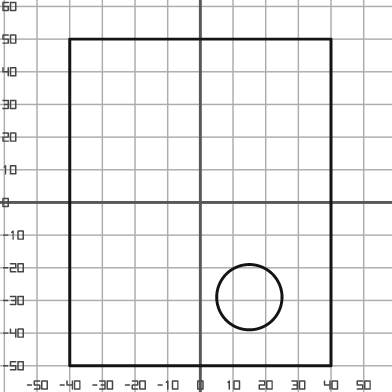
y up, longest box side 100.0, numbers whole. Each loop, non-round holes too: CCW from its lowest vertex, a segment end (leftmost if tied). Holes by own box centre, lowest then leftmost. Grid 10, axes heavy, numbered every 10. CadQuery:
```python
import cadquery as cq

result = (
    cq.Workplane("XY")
    .moveTo(-40.0, -50.0)
    .lineTo(40.0, -50.0)
    .lineTo(40.0, 50.0)
    .lineTo(-40.0, 50.0)
    .close()
    .moveTo(15.0, -29.0)
    .circle(10.0)
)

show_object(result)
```